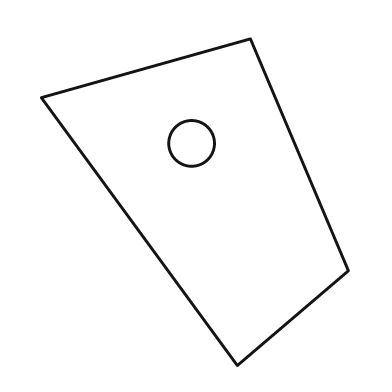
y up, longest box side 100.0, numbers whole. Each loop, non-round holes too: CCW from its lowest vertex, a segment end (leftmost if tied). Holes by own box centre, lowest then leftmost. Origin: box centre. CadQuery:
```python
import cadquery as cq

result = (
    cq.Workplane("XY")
    .moveTo(13.0, -50.0)
    .lineTo(47.0, -21.0)
    .lineTo(17.0, 50.0)
    .lineTo(-47.0, 32.0)
    .close()
    .moveTo(-1.0, 18.0)
    .circle(7.0)
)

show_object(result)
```